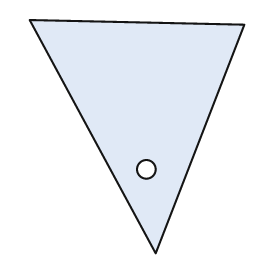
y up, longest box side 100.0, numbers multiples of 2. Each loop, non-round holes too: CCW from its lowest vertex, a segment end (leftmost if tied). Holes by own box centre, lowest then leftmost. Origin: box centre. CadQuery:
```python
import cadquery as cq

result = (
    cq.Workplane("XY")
    .moveTo(8.0, -50.0)
    .lineTo(46.0, 48.0)
    .lineTo(-46.0, 50.0)
    .close()
    .moveTo(4.0, -14.0)
    .circle(4.0)
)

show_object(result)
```